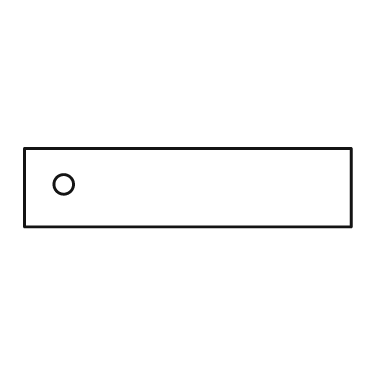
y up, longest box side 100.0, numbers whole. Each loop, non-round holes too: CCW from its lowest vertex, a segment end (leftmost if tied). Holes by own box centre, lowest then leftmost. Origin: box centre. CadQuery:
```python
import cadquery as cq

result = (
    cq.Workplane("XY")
    .moveTo(-50.0, -12.0)
    .lineTo(50.0, -12.0)
    .lineTo(50.0, 12.0)
    .lineTo(-50.0, 12.0)
    .close()
    .moveTo(-38.0, 1.0)
    .circle(3.0)
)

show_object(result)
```